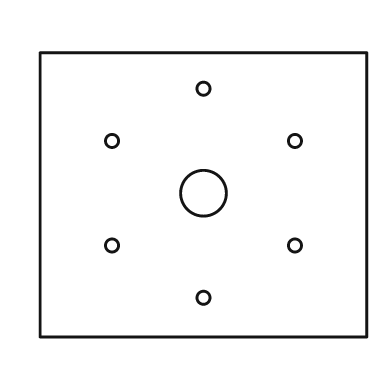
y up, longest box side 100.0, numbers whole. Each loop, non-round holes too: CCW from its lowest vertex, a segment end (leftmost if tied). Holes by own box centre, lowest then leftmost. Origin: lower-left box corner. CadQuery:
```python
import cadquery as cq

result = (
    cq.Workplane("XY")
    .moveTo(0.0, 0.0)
    .lineTo(100.0, 0.0)
    .lineTo(100.0, 87.0)
    .lineTo(0.0, 87.0)
    .close()
    .moveTo(50.0, 12.0)
    .circle(2.0)
    .moveTo(22.0, 28.0)
    .circle(2.0)
    .moveTo(78.0, 28.0)
    .circle(2.0)
    .moveTo(50.0, 44.0)
    .circle(7.0)
    .moveTo(22.0, 60.0)
    .circle(2.0)
    .moveTo(78.0, 60.0)
    .circle(2.0)
    .moveTo(50.0, 76.0)
    .circle(2.0)
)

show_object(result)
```